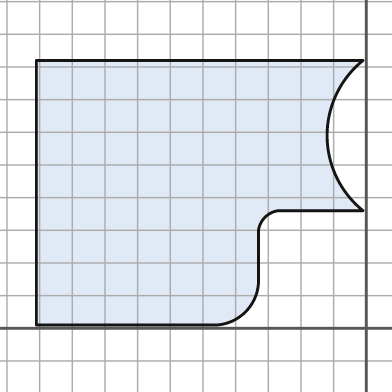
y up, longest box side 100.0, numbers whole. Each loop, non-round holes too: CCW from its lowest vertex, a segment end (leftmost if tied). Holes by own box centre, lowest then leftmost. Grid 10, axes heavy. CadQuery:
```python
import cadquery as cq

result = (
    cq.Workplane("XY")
    .moveTo(-101.0, 1.0)
    .lineTo(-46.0, 1.0)
    .threePointArc((-37.0, 5.0), (-33.0, 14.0))
    .lineTo(-33.0, 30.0)
    .threePointArc((-31.0, 34.0), (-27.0, 36.0))
    .lineTo(-1.0, 36.0)
    .threePointArc((-12.0, 59.0), (-1.0, 82.0))
    .lineTo(-101.0, 82.0)
    .close()
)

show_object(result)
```